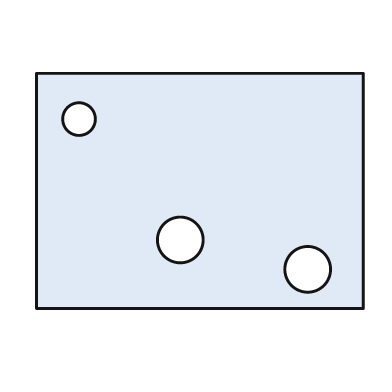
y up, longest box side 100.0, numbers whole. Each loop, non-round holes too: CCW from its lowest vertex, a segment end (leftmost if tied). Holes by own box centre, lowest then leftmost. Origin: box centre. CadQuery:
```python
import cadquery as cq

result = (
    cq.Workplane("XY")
    .moveTo(-50.0, -36.0)
    .lineTo(50.0, -36.0)
    .lineTo(50.0, 36.0)
    .lineTo(-50.0, 36.0)
    .close()
    .moveTo(33.0, -24.0)
    .circle(7.0)
    .moveTo(-6.0, -15.0)
    .circle(7.0)
    .moveTo(-37.0, 22.0)
    .circle(5.0)
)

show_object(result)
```